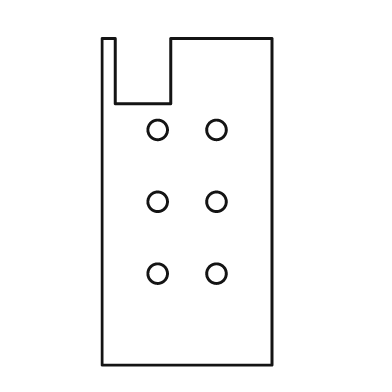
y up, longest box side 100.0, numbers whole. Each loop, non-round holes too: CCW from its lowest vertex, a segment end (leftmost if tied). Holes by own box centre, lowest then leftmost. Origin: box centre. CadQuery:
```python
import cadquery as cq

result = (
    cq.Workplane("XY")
    .moveTo(-26.0, -50.0)
    .lineTo(26.0, -50.0)
    .lineTo(26.0, 50.0)
    .lineTo(-5.0, 50.0)
    .lineTo(-5.0, 30.0)
    .lineTo(-22.0, 30.0)
    .lineTo(-22.0, 50.0)
    .lineTo(-26.0, 50.0)
    .close()
    .moveTo(-9.0, -22.0)
    .circle(3.0)
    .moveTo(9.0, -22.0)
    .circle(3.0)
    .moveTo(-9.0, 0.0)
    .circle(3.0)
    .moveTo(9.0, 0.0)
    .circle(3.0)
    .moveTo(-9.0, 22.0)
    .circle(3.0)
    .moveTo(9.0, 22.0)
    .circle(3.0)
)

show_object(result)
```